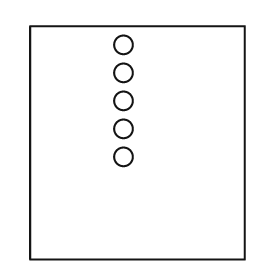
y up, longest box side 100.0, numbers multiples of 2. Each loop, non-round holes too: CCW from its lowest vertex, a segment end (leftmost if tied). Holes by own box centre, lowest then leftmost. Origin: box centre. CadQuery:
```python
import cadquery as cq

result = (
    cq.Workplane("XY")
    .moveTo(-46.0, -50.0)
    .lineTo(46.0, -50.0)
    .lineTo(46.0, 50.0)
    .lineTo(-46.0, 50.0)
    .close()
    .moveTo(-6.0, -6.0)
    .circle(4.0)
    .moveTo(-6.0, 6.0)
    .circle(4.0)
    .moveTo(-6.0, 18.0)
    .circle(4.0)
    .moveTo(-6.0, 30.0)
    .circle(4.0)
    .moveTo(-6.0, 42.0)
    .circle(4.0)
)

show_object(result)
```